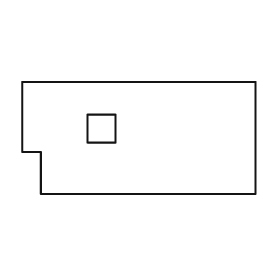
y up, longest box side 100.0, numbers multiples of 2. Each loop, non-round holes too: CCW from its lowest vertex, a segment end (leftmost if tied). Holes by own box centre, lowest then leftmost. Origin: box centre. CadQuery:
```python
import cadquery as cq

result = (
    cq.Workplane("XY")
    .moveTo(-42.0, -24.0)
    .lineTo(50.0, -24.0)
    .lineTo(50.0, 24.0)
    .lineTo(-50.0, 24.0)
    .lineTo(-50.0, -6.0)
    .lineTo(-42.0, -6.0)
    .close()
    .moveTo(-22.0, -2.0)
    .lineTo(-10.0, -2.0)
    .lineTo(-10.0, 10.0)
    .lineTo(-22.0, 10.0)
    .close()
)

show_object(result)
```